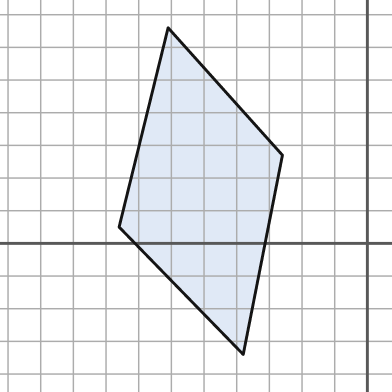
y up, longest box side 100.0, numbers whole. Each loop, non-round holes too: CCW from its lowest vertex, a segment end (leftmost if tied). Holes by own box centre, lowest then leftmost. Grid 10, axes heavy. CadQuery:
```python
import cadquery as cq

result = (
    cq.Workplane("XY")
    .moveTo(-38.0, -34.0)
    .lineTo(-26.0, 27.0)
    .lineTo(-61.0, 66.0)
    .lineTo(-76.0, 5.0)
    .close()
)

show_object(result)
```